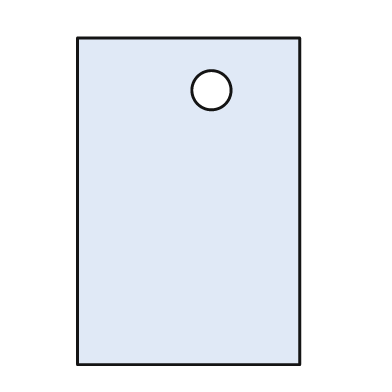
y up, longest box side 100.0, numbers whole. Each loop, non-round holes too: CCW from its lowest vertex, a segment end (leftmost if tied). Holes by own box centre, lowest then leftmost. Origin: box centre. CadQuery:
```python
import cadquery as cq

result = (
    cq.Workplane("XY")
    .moveTo(-34.0, -50.0)
    .lineTo(34.0, -50.0)
    .lineTo(34.0, 50.0)
    .lineTo(-34.0, 50.0)
    .close()
    .moveTo(7.0, 34.0)
    .circle(6.0)
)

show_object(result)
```